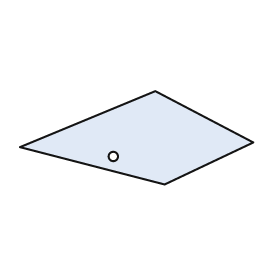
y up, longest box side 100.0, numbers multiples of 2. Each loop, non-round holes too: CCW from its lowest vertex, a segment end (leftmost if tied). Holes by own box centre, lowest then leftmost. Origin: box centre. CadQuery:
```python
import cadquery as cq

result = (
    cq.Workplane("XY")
    .moveTo(12.0, -20.0)
    .lineTo(50.0, -2.0)
    .lineTo(8.0, 20.0)
    .lineTo(-50.0, -4.0)
    .close()
    .moveTo(-10.0, -8.0)
    .circle(2.0)
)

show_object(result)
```